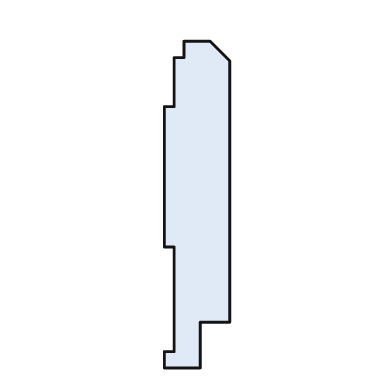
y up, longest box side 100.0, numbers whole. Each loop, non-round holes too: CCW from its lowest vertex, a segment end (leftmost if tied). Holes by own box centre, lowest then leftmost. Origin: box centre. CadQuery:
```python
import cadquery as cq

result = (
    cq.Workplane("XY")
    .moveTo(-10.0, -50.0)
    .lineTo(1.0, -50.0)
    .lineTo(1.0, -36.0)
    .lineTo(10.0, -36.0)
    .lineTo(10.0, 44.0)
    .lineTo(4.0, 50.0)
    .lineTo(-4.0, 50.0)
    .lineTo(-4.0, 45.0)
    .lineTo(-7.0, 45.0)
    .lineTo(-7.0, 30.0)
    .lineTo(-10.0, 30.0)
    .lineTo(-10.0, -13.0)
    .lineTo(-7.0, -13.0)
    .lineTo(-7.0, -45.0)
    .lineTo(-10.0, -45.0)
    .close()
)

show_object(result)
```